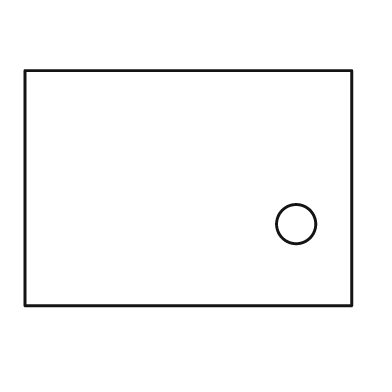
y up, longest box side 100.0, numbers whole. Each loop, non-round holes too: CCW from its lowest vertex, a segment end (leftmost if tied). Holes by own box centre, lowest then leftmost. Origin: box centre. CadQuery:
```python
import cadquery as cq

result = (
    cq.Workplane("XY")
    .moveTo(-50.0, -36.0)
    .lineTo(50.0, -36.0)
    .lineTo(50.0, 36.0)
    .lineTo(-50.0, 36.0)
    .close()
    .moveTo(33.0, -11.0)
    .circle(6.0)
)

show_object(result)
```